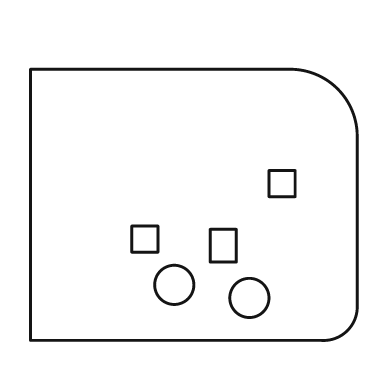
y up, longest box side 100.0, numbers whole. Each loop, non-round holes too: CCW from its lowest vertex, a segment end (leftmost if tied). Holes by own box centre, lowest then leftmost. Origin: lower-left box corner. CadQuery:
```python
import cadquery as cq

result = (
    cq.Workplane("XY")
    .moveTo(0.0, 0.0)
    .lineTo(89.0, 0.0)
    .threePointArc((97.0, 3.0), (100.0, 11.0))
    .lineTo(100.0, 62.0)
    .threePointArc((94.0, 77.0), (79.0, 83.0))
    .lineTo(0.0, 83.0)
    .close()
    .moveTo(67.0, 13.0)
    .circle(6.0)
    .moveTo(44.0, 17.0)
    .circle(6.0)
    .moveTo(55.0, 24.0)
    .lineTo(63.0, 24.0)
    .lineTo(63.0, 34.0)
    .lineTo(55.0, 34.0)
    .close()
    .moveTo(31.0, 27.0)
    .lineTo(39.0, 27.0)
    .lineTo(39.0, 35.0)
    .lineTo(31.0, 35.0)
    .close()
    .moveTo(73.0, 44.0)
    .lineTo(81.0, 44.0)
    .lineTo(81.0, 52.0)
    .lineTo(73.0, 52.0)
    .close()
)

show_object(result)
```